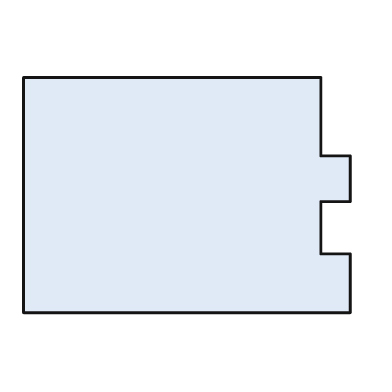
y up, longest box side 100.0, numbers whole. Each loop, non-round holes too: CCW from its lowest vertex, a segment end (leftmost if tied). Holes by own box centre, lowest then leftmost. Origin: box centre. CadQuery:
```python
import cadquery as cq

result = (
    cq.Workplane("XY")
    .moveTo(-50.0, -36.0)
    .lineTo(50.0, -36.0)
    .lineTo(50.0, -18.0)
    .lineTo(41.0, -18.0)
    .lineTo(41.0, -2.0)
    .lineTo(50.0, -2.0)
    .lineTo(50.0, 12.0)
    .lineTo(41.0, 12.0)
    .lineTo(41.0, 36.0)
    .lineTo(-50.0, 36.0)
    .close()
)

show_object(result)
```